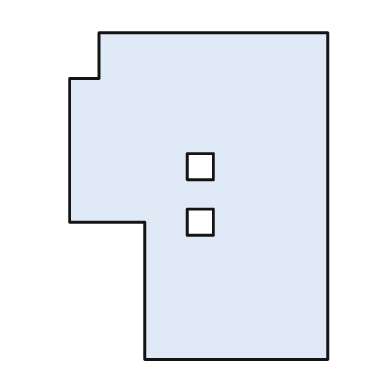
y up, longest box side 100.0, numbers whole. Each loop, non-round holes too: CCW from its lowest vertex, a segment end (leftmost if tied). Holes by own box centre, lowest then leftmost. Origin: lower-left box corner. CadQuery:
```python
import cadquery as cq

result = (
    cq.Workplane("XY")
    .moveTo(23.0, 0.0)
    .lineTo(79.0, 0.0)
    .lineTo(79.0, 100.0)
    .lineTo(9.0, 100.0)
    .lineTo(9.0, 86.0)
    .lineTo(0.0, 86.0)
    .lineTo(0.0, 42.0)
    .lineTo(23.0, 42.0)
    .close()
    .moveTo(36.0, 38.0)
    .lineTo(44.0, 38.0)
    .lineTo(44.0, 46.0)
    .lineTo(36.0, 46.0)
    .close()
    .moveTo(36.0, 55.0)
    .lineTo(44.0, 55.0)
    .lineTo(44.0, 63.0)
    .lineTo(36.0, 63.0)
    .close()
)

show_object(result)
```